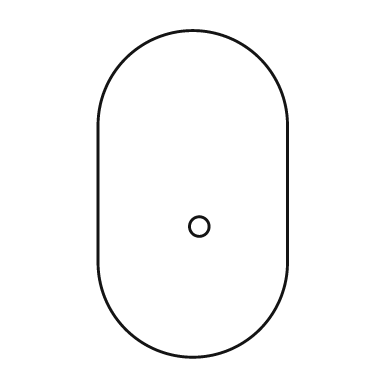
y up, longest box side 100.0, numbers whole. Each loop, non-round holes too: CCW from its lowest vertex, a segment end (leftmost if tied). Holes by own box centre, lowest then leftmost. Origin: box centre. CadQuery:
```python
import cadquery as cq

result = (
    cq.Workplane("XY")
    .moveTo(-29.0, -21.0)
    .threePointArc((0.0, -50.0), (29.0, -21.0))
    .lineTo(29.0, 21.0)
    .threePointArc((0.0, 50.0), (-29.0, 21.0))
    .close()
    .moveTo(2.0, -10.0)
    .circle(3.0)
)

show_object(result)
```